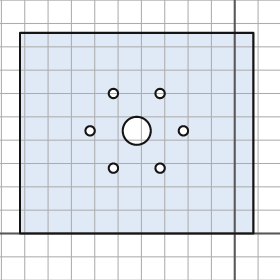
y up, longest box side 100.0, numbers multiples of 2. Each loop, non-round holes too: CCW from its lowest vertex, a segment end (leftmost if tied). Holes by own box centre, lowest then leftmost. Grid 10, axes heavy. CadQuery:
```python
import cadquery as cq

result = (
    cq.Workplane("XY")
    .moveTo(-92.0, 0.0)
    .lineTo(8.0, 0.0)
    .lineTo(8.0, 86.0)
    .lineTo(-92.0, 86.0)
    .close()
    .moveTo(-52.0, 28.0)
    .circle(2.0)
    .moveTo(-32.0, 28.0)
    .circle(2.0)
    .moveTo(-62.0, 44.0)
    .circle(2.0)
    .moveTo(-42.0, 44.0)
    .circle(6.0)
    .moveTo(-22.0, 44.0)
    .circle(2.0)
    .moveTo(-52.0, 60.0)
    .circle(2.0)
    .moveTo(-32.0, 60.0)
    .circle(2.0)
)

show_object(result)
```